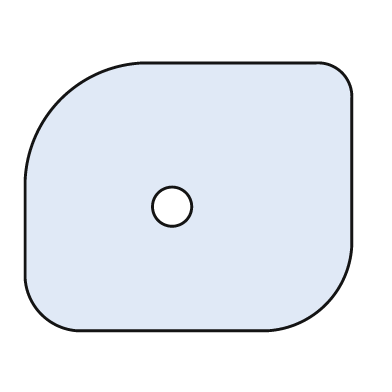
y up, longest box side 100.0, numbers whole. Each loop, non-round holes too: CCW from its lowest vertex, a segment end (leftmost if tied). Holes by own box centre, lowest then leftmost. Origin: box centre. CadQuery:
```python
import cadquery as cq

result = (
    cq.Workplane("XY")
    .moveTo(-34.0, -41.0)
    .lineTo(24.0, -41.0)
    .threePointArc((42.0, -33.0), (50.0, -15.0))
    .lineTo(50.0, 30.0)
    .threePointArc((47.0, 38.0), (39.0, 41.0))
    .lineTo(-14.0, 41.0)
    .threePointArc((-39.0, 30.0), (-50.0, 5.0))
    .lineTo(-50.0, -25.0)
    .threePointArc((-45.0, -36.0), (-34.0, -41.0))
    .close()
    .moveTo(-5.0, -3.0)
    .circle(6.0)
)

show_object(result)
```